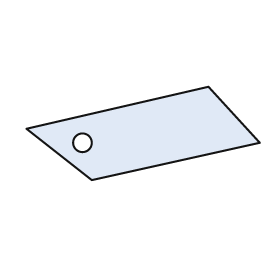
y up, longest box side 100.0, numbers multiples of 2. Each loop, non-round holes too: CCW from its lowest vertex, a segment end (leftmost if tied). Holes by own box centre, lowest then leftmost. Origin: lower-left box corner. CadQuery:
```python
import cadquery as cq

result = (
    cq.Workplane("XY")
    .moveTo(28.0, 0.0)
    .lineTo(100.0, 16.0)
    .lineTo(78.0, 40.0)
    .lineTo(0.0, 22.0)
    .close()
    .moveTo(24.0, 16.0)
    .circle(4.0)
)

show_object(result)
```